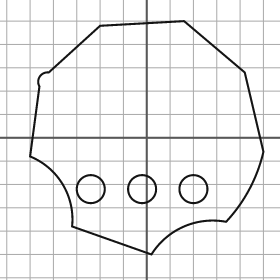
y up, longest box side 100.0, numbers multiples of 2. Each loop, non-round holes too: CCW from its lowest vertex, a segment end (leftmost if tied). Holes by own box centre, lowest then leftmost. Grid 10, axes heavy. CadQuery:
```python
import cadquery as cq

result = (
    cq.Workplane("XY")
    .moveTo(2.0, -50.0)
    .threePointArc((16.0, -38.0), (34.0, -36.0))
    .threePointArc((44.0, -22.0), (50.0, -6.0))
    .lineTo(42.0, 28.0)
    .lineTo(16.0, 50.0)
    .lineTo(-20.0, 48.0)
    .lineTo(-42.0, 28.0)
    .threePointArc((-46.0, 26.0), (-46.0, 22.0))
    .lineTo(-50.0, -8.0)
    .threePointArc((-36.0, -20.0), (-32.0, -38.0))
    .close()
    .moveTo(-24.0, -22.0)
    .circle(6.0)
    .moveTo(-2.0, -22.0)
    .circle(6.0)
    .moveTo(20.0, -22.0)
    .circle(6.0)
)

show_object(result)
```